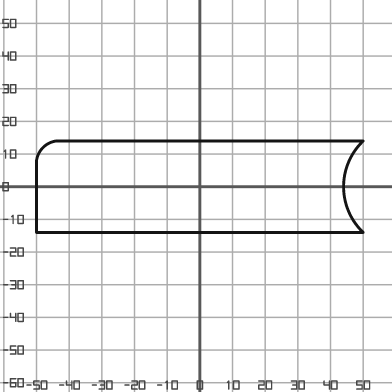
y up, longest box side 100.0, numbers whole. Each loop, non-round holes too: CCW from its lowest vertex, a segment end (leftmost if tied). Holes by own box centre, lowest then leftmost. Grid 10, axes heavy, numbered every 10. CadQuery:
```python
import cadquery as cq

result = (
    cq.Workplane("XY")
    .moveTo(-50.0, -14.0)
    .lineTo(50.0, -14.0)
    .threePointArc((44.0, 0.0), (50.0, 14.0))
    .lineTo(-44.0, 14.0)
    .threePointArc((-48.0, 12.0), (-50.0, 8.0))
    .close()
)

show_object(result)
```